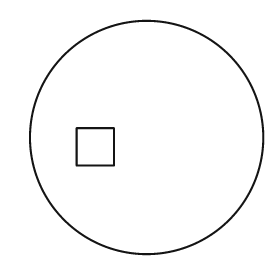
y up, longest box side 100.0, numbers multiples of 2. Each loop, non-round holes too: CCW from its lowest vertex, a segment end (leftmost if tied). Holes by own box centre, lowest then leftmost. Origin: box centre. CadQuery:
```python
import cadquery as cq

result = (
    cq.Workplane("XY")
    .moveTo(0.0, 0.0)
    .circle(50.0)
    .moveTo(-30.0, -12.0)
    .lineTo(-14.0, -12.0)
    .lineTo(-14.0, 4.0)
    .lineTo(-30.0, 4.0)
    .close()
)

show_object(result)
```